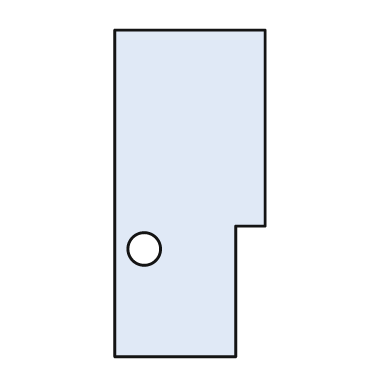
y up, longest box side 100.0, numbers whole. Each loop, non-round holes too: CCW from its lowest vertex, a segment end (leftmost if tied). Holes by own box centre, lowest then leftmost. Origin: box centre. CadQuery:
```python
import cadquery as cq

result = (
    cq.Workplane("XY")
    .moveTo(-23.0, -50.0)
    .lineTo(14.0, -50.0)
    .lineTo(14.0, -10.0)
    .lineTo(23.0, -10.0)
    .lineTo(23.0, 50.0)
    .lineTo(-23.0, 50.0)
    .close()
    .moveTo(-14.0, -17.0)
    .circle(5.0)
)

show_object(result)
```